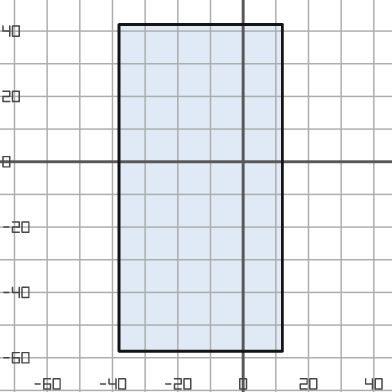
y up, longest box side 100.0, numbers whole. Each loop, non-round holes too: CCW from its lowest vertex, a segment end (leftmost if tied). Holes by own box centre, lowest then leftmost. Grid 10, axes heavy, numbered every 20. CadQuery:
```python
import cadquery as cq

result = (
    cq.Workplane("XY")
    .moveTo(-38.0, -58.0)
    .lineTo(12.0, -58.0)
    .lineTo(12.0, 42.0)
    .lineTo(-38.0, 42.0)
    .close()
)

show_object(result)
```